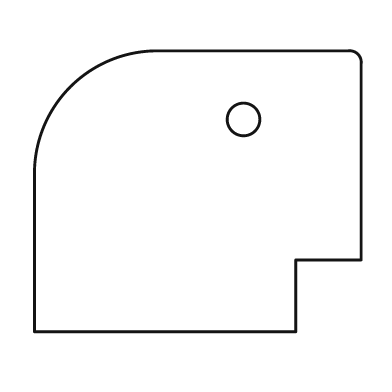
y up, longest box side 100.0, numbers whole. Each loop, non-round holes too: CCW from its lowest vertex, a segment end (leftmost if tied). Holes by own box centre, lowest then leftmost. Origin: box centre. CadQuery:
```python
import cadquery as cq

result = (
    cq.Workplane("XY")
    .moveTo(-50.0, -43.0)
    .lineTo(30.0, -43.0)
    .lineTo(30.0, -21.0)
    .lineTo(50.0, -21.0)
    .lineTo(50.0, 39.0)
    .threePointArc((49.0, 42.0), (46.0, 43.0))
    .lineTo(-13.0, 43.0)
    .threePointArc((-39.0, 32.0), (-50.0, 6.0))
    .close()
    .moveTo(14.0, 22.0)
    .circle(5.0)
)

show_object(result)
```